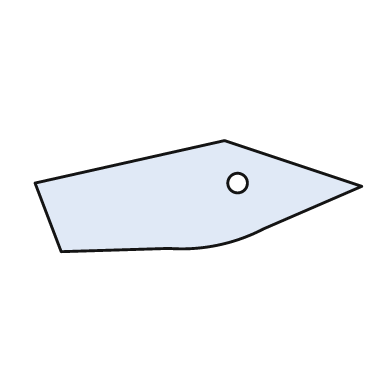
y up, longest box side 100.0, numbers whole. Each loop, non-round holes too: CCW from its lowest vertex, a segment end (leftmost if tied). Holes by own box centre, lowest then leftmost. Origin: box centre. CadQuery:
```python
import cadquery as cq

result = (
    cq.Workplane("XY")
    .moveTo(-42.0, -17.0)
    .lineTo(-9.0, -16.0)
    .threePointArc((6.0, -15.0), (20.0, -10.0))
    .lineTo(50.0, 3.0)
    .lineTo(8.0, 17.0)
    .lineTo(-50.0, 4.0)
    .close()
    .moveTo(12.0, 4.0)
    .circle(3.0)
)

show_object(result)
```